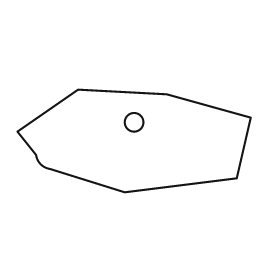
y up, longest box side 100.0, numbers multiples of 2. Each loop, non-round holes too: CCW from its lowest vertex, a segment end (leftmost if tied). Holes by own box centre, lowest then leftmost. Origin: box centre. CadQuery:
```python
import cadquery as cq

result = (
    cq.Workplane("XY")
    .moveTo(-4.0, -22.0)
    .lineTo(44.0, -16.0)
    .lineTo(50.0, 10.0)
    .lineTo(14.0, 20.0)
    .lineTo(-24.0, 22.0)
    .lineTo(-50.0, 4.0)
    .lineTo(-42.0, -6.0)
    .threePointArc((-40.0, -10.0), (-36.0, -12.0))
    .close()
    .moveTo(0.0, 8.0)
    .circle(4.0)
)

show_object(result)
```